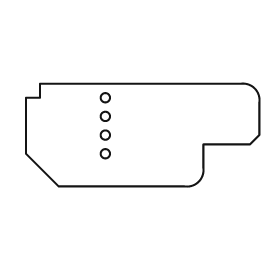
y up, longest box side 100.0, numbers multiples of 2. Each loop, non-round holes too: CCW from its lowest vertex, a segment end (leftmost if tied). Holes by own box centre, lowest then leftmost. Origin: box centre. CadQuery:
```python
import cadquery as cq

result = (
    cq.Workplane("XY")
    .moveTo(-36.0, -22.0)
    .lineTo(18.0, -22.0)
    .threePointArc((24.0, -20.0), (26.0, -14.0))
    .lineTo(26.0, -4.0)
    .lineTo(46.0, -4.0)
    .lineTo(50.0, 0.0)
    .lineTo(50.0, 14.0)
    .threePointArc((48.0, 20.0), (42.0, 22.0))
    .lineTo(-44.0, 22.0)
    .lineTo(-44.0, 16.0)
    .lineTo(-50.0, 16.0)
    .lineTo(-50.0, -8.0)
    .close()
    .moveTo(-16.0, -8.0)
    .circle(2.0)
    .moveTo(-16.0, 0.0)
    .circle(2.0)
    .moveTo(-16.0, 8.0)
    .circle(2.0)
    .moveTo(-16.0, 16.0)
    .circle(2.0)
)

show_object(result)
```